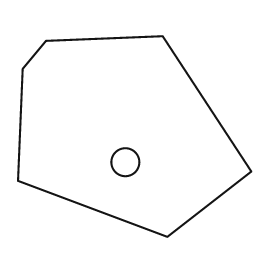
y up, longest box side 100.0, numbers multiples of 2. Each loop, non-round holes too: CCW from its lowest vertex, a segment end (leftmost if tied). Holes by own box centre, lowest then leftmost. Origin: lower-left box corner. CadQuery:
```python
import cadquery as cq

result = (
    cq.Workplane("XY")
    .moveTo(64.0, 0.0)
    .lineTo(100.0, 28.0)
    .lineTo(62.0, 86.0)
    .lineTo(12.0, 84.0)
    .lineTo(2.0, 72.0)
    .lineTo(0.0, 24.0)
    .close()
    .moveTo(46.0, 32.0)
    .circle(6.0)
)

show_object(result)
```